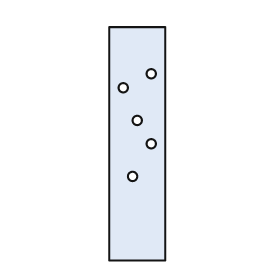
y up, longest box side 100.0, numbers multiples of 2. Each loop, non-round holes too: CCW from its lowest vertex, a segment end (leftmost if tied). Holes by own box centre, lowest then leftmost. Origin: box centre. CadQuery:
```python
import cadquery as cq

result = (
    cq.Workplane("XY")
    .moveTo(-12.0, -50.0)
    .lineTo(12.0, -50.0)
    .lineTo(12.0, 50.0)
    .lineTo(-12.0, 50.0)
    .close()
    .moveTo(-2.0, -14.0)
    .circle(2.0)
    .moveTo(6.0, 0.0)
    .circle(2.0)
    .moveTo(0.0, 10.0)
    .circle(2.0)
    .moveTo(-6.0, 24.0)
    .circle(2.0)
    .moveTo(6.0, 30.0)
    .circle(2.0)
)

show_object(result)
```